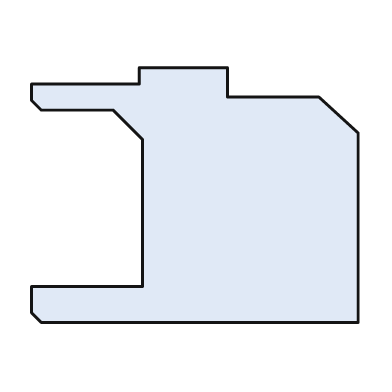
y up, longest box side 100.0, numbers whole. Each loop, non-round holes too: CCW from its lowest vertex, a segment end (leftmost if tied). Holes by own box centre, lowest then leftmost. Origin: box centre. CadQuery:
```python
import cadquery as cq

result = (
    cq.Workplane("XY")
    .moveTo(-47.0, -39.0)
    .lineTo(50.0, -39.0)
    .lineTo(50.0, 19.0)
    .lineTo(38.0, 30.0)
    .lineTo(10.0, 30.0)
    .lineTo(10.0, 39.0)
    .lineTo(-17.0, 39.0)
    .lineTo(-17.0, 34.0)
    .lineTo(-50.0, 34.0)
    .lineTo(-50.0, 29.0)
    .lineTo(-47.0, 26.0)
    .lineTo(-25.0, 26.0)
    .lineTo(-16.0, 17.0)
    .lineTo(-16.0, -28.0)
    .lineTo(-50.0, -28.0)
    .lineTo(-50.0, -36.0)
    .close()
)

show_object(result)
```